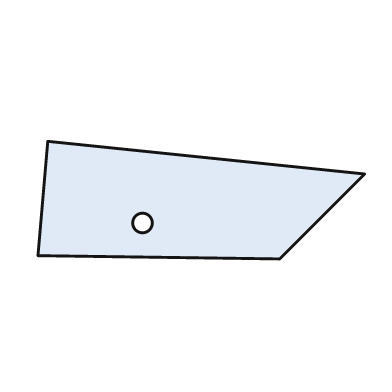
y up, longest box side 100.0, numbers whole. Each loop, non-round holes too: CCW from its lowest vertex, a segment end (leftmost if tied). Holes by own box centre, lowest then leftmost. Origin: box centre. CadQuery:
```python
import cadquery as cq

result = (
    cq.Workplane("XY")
    .moveTo(24.0, -18.0)
    .lineTo(50.0, 8.0)
    .lineTo(-47.0, 18.0)
    .lineTo(-50.0, -17.0)
    .close()
    .moveTo(-18.0, -7.0)
    .circle(3.0)
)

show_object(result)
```